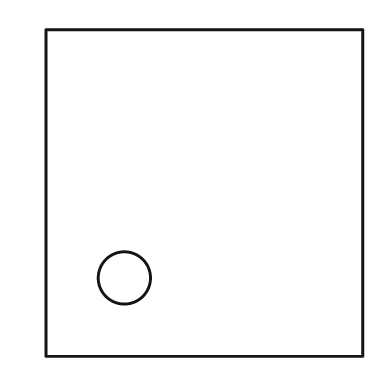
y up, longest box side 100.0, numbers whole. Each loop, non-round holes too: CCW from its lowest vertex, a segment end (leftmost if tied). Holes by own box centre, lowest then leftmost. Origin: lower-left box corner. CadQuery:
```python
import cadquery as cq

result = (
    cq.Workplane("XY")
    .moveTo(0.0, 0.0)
    .lineTo(97.0, 0.0)
    .lineTo(97.0, 100.0)
    .lineTo(0.0, 100.0)
    .close()
    .moveTo(24.0, 24.0)
    .circle(8.0)
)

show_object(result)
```